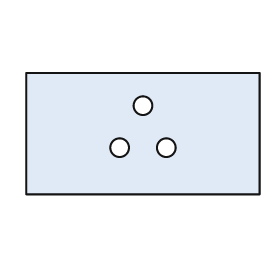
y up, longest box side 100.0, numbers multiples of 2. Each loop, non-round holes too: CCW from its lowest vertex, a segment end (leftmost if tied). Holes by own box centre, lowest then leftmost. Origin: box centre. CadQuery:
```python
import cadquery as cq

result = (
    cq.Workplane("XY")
    .moveTo(-50.0, -26.0)
    .lineTo(50.0, -26.0)
    .lineTo(50.0, 26.0)
    .lineTo(-50.0, 26.0)
    .close()
    .moveTo(-10.0, -6.0)
    .circle(4.0)
    .moveTo(10.0, -6.0)
    .circle(4.0)
    .moveTo(0.0, 12.0)
    .circle(4.0)
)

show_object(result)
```